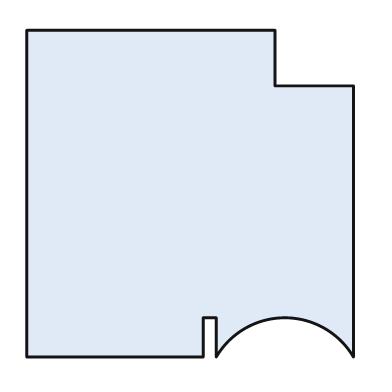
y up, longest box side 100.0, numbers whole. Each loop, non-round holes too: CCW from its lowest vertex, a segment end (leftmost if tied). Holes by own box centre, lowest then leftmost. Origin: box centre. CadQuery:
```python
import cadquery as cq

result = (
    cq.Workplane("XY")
    .moveTo(-50.0, -50.0)
    .lineTo(4.0, -50.0)
    .lineTo(4.0, -38.0)
    .lineTo(8.0, -38.0)
    .lineTo(8.0, -50.0)
    .threePointArc((29.0, -38.0), (50.0, -50.0))
    .lineTo(50.0, 33.0)
    .lineTo(26.0, 33.0)
    .lineTo(26.0, 50.0)
    .lineTo(-50.0, 50.0)
    .close()
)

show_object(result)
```